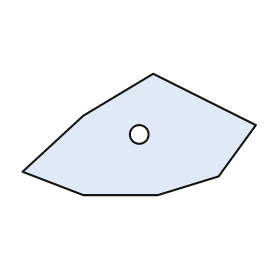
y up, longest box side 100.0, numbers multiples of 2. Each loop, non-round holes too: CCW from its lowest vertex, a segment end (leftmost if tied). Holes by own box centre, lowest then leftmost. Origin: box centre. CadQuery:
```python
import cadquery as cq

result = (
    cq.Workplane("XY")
    .moveTo(-24.0, -26.0)
    .lineTo(8.0, -26.0)
    .lineTo(34.0, -18.0)
    .lineTo(50.0, 4.0)
    .lineTo(6.0, 26.0)
    .lineTo(-24.0, 8.0)
    .lineTo(-50.0, -16.0)
    .close()
    .moveTo(0.0, 0.0)
    .circle(4.0)
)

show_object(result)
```